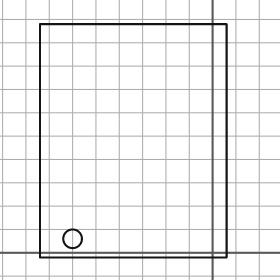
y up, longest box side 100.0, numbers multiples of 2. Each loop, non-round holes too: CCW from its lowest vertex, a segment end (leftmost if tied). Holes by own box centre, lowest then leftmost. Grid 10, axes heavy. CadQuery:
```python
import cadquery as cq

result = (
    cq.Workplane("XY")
    .moveTo(-74.0, -2.0)
    .lineTo(6.0, -2.0)
    .lineTo(6.0, 98.0)
    .lineTo(-74.0, 98.0)
    .close()
    .moveTo(-60.0, 6.0)
    .circle(4.0)
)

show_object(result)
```